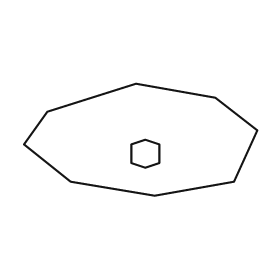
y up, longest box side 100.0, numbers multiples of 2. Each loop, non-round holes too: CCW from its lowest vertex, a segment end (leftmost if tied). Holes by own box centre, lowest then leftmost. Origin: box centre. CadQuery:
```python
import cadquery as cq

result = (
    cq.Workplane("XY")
    .moveTo(6.0, -24.0)
    .lineTo(40.0, -18.0)
    .lineTo(50.0, 4.0)
    .lineTo(32.0, 18.0)
    .lineTo(-2.0, 24.0)
    .lineTo(-40.0, 12.0)
    .lineTo(-50.0, -2.0)
    .lineTo(-30.0, -18.0)
    .close()
    .moveTo(2.0, -12.0)
    .lineTo(8.0, -10.0)
    .lineTo(8.0, -2.0)
    .lineTo(2.0, 0.0)
    .lineTo(-4.0, -2.0)
    .lineTo(-4.0, -10.0)
    .close()
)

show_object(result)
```